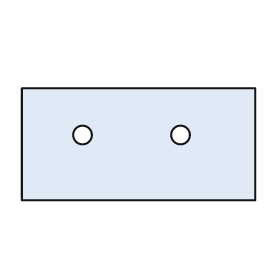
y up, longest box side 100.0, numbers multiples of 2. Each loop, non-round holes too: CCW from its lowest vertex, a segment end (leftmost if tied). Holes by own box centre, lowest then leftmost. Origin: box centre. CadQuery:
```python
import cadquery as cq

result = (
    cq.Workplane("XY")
    .moveTo(-50.0, -24.0)
    .lineTo(50.0, -24.0)
    .lineTo(50.0, 24.0)
    .lineTo(-50.0, 24.0)
    .close()
    .moveTo(-24.0, 4.0)
    .circle(4.0)
    .moveTo(18.0, 4.0)
    .circle(4.0)
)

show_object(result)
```